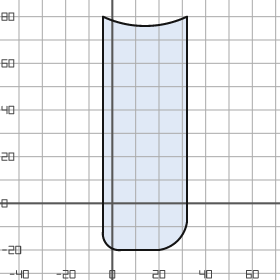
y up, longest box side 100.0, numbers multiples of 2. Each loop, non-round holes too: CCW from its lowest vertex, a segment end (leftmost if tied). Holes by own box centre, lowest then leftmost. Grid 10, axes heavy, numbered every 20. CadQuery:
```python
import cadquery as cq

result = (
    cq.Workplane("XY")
    .moveTo(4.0, -20.0)
    .lineTo(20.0, -20.0)
    .threePointArc((28.0, -16.0), (32.0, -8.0))
    .lineTo(32.0, 80.0)
    .threePointArc((14.0, 76.0), (-4.0, 80.0))
    .lineTo(-4.0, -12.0)
    .threePointArc((-2.0, -18.0), (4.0, -20.0))
    .close()
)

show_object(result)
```